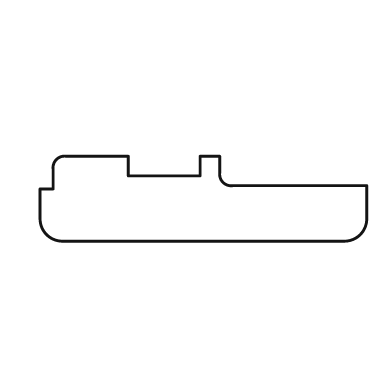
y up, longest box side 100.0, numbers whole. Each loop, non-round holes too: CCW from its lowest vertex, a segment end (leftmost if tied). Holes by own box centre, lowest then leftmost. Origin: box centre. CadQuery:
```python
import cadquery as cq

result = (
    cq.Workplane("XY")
    .moveTo(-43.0, -13.0)
    .lineTo(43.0, -13.0)
    .threePointArc((48.0, -11.0), (50.0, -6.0))
    .lineTo(50.0, 4.0)
    .lineTo(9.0, 4.0)
    .threePointArc((6.0, 5.0), (5.0, 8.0))
    .lineTo(5.0, 13.0)
    .lineTo(-1.0, 13.0)
    .lineTo(-1.0, 7.0)
    .lineTo(-23.0, 7.0)
    .lineTo(-23.0, 13.0)
    .lineTo(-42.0, 13.0)
    .threePointArc((-45.0, 12.0), (-46.0, 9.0))
    .lineTo(-46.0, 3.0)
    .lineTo(-50.0, 3.0)
    .lineTo(-50.0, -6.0)
    .threePointArc((-48.0, -11.0), (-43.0, -13.0))
    .close()
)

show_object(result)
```